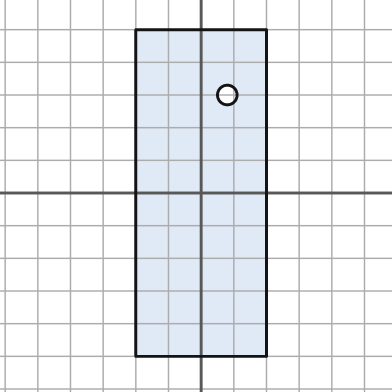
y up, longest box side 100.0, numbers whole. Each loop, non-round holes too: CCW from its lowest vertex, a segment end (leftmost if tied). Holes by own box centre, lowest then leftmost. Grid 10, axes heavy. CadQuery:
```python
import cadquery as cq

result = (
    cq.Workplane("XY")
    .moveTo(-20.0, -50.0)
    .lineTo(20.0, -50.0)
    .lineTo(20.0, 50.0)
    .lineTo(-20.0, 50.0)
    .close()
    .moveTo(8.0, 30.0)
    .circle(3.0)
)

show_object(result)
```